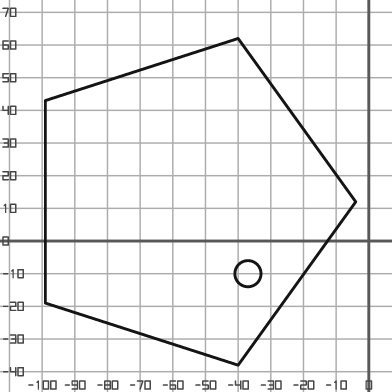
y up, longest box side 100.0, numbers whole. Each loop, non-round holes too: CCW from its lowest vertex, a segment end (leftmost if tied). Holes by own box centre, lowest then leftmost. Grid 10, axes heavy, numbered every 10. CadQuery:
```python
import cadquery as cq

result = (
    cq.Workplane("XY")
    .moveTo(-40.0, -38.0)
    .lineTo(-4.0, 12.0)
    .lineTo(-40.0, 62.0)
    .lineTo(-99.0, 43.0)
    .lineTo(-99.0, -19.0)
    .close()
    .moveTo(-37.0, -10.0)
    .circle(4.0)
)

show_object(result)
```